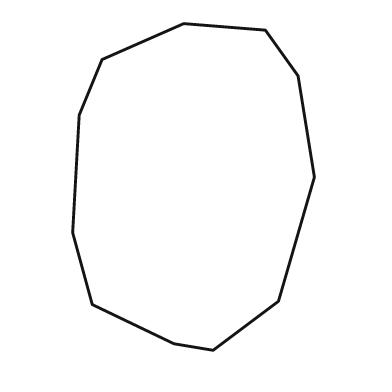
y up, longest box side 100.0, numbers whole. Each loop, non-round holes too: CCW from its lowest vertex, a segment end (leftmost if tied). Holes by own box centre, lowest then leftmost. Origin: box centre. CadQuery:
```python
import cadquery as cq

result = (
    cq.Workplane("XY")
    .moveTo(6.0, -50.0)
    .lineTo(26.0, -35.0)
    .lineTo(37.0, 3.0)
    .lineTo(32.0, 34.0)
    .lineTo(22.0, 48.0)
    .lineTo(-3.0, 50.0)
    .lineTo(-28.0, 39.0)
    .lineTo(-35.0, 22.0)
    .lineTo(-37.0, -14.0)
    .lineTo(-31.0, -36.0)
    .lineTo(-6.0, -48.0)
    .close()
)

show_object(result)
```